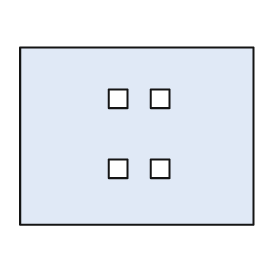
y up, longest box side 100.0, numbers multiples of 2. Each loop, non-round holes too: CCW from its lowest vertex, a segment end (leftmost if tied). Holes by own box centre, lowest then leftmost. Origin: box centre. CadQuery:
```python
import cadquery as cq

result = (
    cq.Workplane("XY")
    .moveTo(-50.0, -38.0)
    .lineTo(50.0, -38.0)
    .lineTo(50.0, 38.0)
    .lineTo(-50.0, 38.0)
    .close()
    .moveTo(-12.0, -18.0)
    .lineTo(-4.0, -18.0)
    .lineTo(-4.0, -10.0)
    .lineTo(-12.0, -10.0)
    .close()
    .moveTo(6.0, -18.0)
    .lineTo(14.0, -18.0)
    .lineTo(14.0, -10.0)
    .lineTo(6.0, -10.0)
    .close()
    .moveTo(-12.0, 12.0)
    .lineTo(-4.0, 12.0)
    .lineTo(-4.0, 20.0)
    .lineTo(-12.0, 20.0)
    .close()
    .moveTo(6.0, 12.0)
    .lineTo(14.0, 12.0)
    .lineTo(14.0, 20.0)
    .lineTo(6.0, 20.0)
    .close()
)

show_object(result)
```